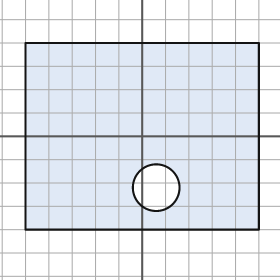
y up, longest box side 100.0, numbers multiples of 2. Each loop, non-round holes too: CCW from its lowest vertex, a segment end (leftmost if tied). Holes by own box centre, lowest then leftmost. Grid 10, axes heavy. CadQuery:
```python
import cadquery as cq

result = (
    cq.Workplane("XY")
    .moveTo(-50.0, -40.0)
    .lineTo(50.0, -40.0)
    .lineTo(50.0, 40.0)
    .lineTo(-50.0, 40.0)
    .close()
    .moveTo(6.0, -22.0)
    .circle(10.0)
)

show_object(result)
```